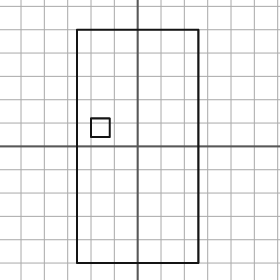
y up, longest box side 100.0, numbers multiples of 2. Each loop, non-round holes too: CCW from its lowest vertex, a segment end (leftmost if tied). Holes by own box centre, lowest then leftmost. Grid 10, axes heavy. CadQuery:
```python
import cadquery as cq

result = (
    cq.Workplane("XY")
    .moveTo(-26.0, -50.0)
    .lineTo(26.0, -50.0)
    .lineTo(26.0, 50.0)
    .lineTo(-26.0, 50.0)
    .close()
    .moveTo(-20.0, 4.0)
    .lineTo(-12.0, 4.0)
    .lineTo(-12.0, 12.0)
    .lineTo(-20.0, 12.0)
    .close()
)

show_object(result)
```